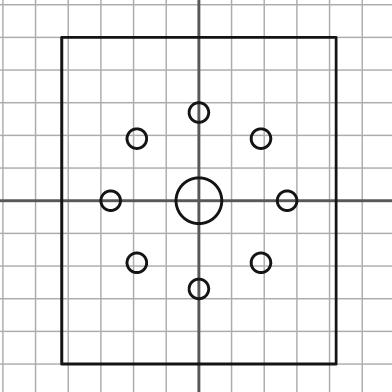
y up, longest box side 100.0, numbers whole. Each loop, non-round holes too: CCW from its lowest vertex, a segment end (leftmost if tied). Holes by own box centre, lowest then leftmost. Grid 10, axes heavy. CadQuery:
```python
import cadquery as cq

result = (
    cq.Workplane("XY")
    .moveTo(-42.0, -50.0)
    .lineTo(42.0, -50.0)
    .lineTo(42.0, 50.0)
    .lineTo(-42.0, 50.0)
    .close()
    .moveTo(0.0, -27.0)
    .circle(3.0)
    .moveTo(-19.0, -19.0)
    .circle(3.0)
    .moveTo(19.0, -19.0)
    .circle(3.0)
    .moveTo(-27.0, 0.0)
    .circle(3.0)
    .moveTo(0.0, 0.0)
    .circle(7.0)
    .moveTo(27.0, 0.0)
    .circle(3.0)
    .moveTo(-19.0, 19.0)
    .circle(3.0)
    .moveTo(19.0, 19.0)
    .circle(3.0)
    .moveTo(0.0, 27.0)
    .circle(3.0)
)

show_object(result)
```